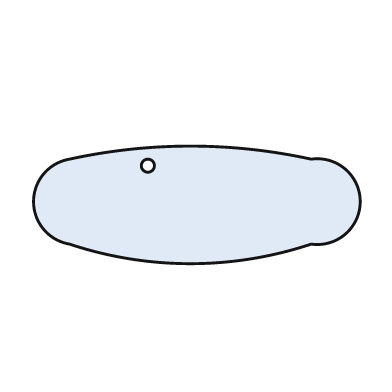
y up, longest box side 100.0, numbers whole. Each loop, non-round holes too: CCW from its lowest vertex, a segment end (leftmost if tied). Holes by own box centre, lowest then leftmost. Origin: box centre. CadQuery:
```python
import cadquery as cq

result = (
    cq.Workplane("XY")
    .moveTo(-39.0, -12.0)
    .threePointArc((-2.0, -18.0), (35.0, -12.0))
    .threePointArc((50.0, 1.0), (35.0, 14.0))
    .threePointArc((-2.0, 18.0), (-39.0, 14.0))
    .threePointArc((-50.0, 1.0), (-39.0, -12.0))
    .close()
    .moveTo(-15.0, 12.0)
    .circle(2.0)
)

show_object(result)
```